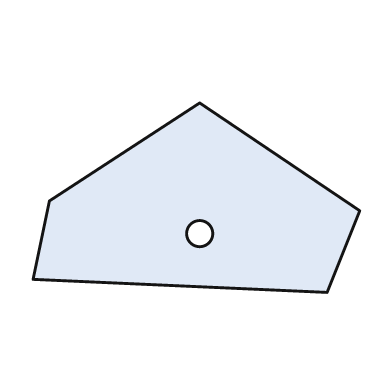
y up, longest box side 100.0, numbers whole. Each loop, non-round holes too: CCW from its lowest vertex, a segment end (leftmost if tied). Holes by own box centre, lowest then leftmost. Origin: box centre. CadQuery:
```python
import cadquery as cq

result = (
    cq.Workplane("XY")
    .moveTo(40.0, -29.0)
    .lineTo(50.0, -4.0)
    .lineTo(1.0, 29.0)
    .lineTo(-45.0, -1.0)
    .lineTo(-50.0, -25.0)
    .close()
    .moveTo(1.0, -11.0)
    .circle(4.0)
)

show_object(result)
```